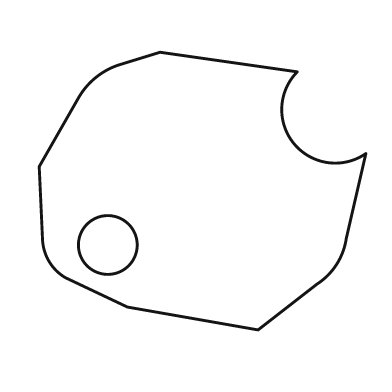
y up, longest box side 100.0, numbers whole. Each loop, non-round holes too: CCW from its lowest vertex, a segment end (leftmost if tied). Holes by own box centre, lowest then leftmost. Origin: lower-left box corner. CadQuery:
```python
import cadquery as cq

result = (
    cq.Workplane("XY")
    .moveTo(67.0, 0.0)
    .lineTo(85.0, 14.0)
    .threePointArc((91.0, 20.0), (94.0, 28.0))
    .lineTo(100.0, 54.0)
    .threePointArc((78.0, 57.0), (79.0, 79.0))
    .lineTo(37.0, 85.0)
    .lineTo(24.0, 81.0)
    .threePointArc((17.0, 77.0), (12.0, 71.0))
    .lineTo(0.0, 50.0)
    .lineTo(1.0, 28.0)
    .threePointArc((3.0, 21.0), (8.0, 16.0))
    .lineTo(27.0, 7.0)
    .close()
    .moveTo(21.0, 26.0)
    .circle(9.0)
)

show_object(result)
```